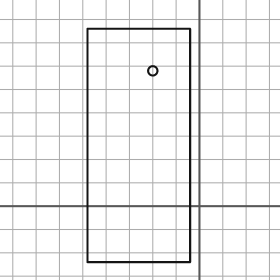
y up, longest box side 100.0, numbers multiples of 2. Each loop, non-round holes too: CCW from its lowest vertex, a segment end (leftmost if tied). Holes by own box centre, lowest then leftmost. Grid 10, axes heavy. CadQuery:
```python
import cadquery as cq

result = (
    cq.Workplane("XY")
    .moveTo(-48.0, -24.0)
    .lineTo(-4.0, -24.0)
    .lineTo(-4.0, 76.0)
    .lineTo(-48.0, 76.0)
    .close()
    .moveTo(-20.0, 58.0)
    .circle(2.0)
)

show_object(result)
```